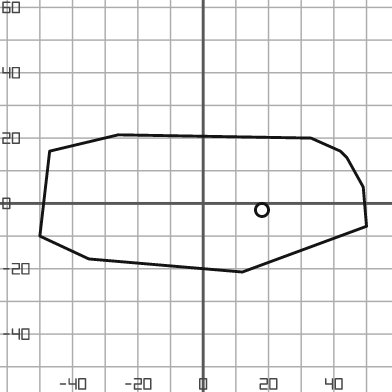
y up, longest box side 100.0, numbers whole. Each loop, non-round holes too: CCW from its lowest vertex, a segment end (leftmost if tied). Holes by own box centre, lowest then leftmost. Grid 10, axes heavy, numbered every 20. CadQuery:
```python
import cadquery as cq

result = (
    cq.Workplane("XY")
    .moveTo(12.0, -21.0)
    .lineTo(50.0, -7.0)
    .lineTo(49.0, 5.0)
    .lineTo(44.0, 14.0)
    .lineTo(42.0, 16.0)
    .lineTo(33.0, 20.0)
    .lineTo(-26.0, 21.0)
    .lineTo(-47.0, 16.0)
    .lineTo(-50.0, -10.0)
    .lineTo(-35.0, -17.0)
    .close()
    .moveTo(18.0, -2.0)
    .circle(2.0)
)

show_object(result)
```